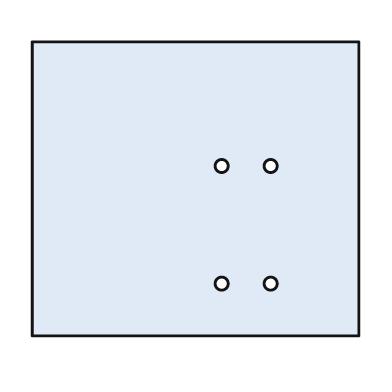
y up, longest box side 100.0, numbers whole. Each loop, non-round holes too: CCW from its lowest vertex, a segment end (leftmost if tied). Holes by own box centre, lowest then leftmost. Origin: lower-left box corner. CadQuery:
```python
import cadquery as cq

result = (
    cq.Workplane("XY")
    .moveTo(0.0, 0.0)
    .lineTo(100.0, 0.0)
    .lineTo(100.0, 90.0)
    .lineTo(0.0, 90.0)
    .close()
    .moveTo(58.0, 16.0)
    .circle(2.0)
    .moveTo(73.0, 16.0)
    .circle(2.0)
    .moveTo(58.0, 52.0)
    .circle(2.0)
    .moveTo(73.0, 52.0)
    .circle(2.0)
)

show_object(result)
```